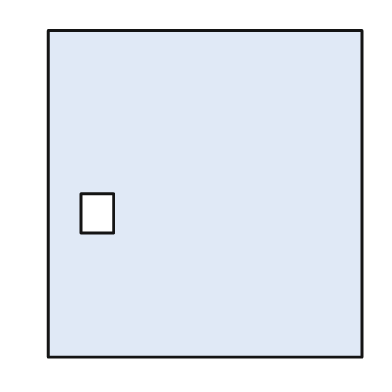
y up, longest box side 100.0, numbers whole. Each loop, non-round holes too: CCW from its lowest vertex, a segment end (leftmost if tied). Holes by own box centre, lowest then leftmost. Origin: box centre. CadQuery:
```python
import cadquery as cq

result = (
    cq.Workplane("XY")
    .moveTo(-48.0, -50.0)
    .lineTo(48.0, -50.0)
    .lineTo(48.0, 50.0)
    .lineTo(-48.0, 50.0)
    .close()
    .moveTo(-38.0, -12.0)
    .lineTo(-28.0, -12.0)
    .lineTo(-28.0, 0.0)
    .lineTo(-38.0, 0.0)
    .close()
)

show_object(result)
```